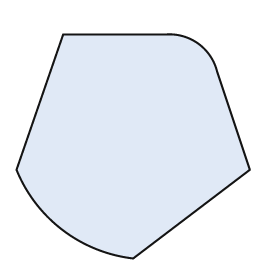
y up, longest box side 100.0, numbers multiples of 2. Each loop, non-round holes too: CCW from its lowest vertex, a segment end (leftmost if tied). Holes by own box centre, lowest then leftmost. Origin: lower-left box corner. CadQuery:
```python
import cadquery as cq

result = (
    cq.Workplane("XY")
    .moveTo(50.0, 0.0)
    .lineTo(100.0, 38.0)
    .lineTo(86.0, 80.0)
    .threePointArc((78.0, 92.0), (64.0, 96.0))
    .lineTo(20.0, 96.0)
    .lineTo(0.0, 38.0)
    .threePointArc((20.0, 12.0), (50.0, 0.0))
    .close()
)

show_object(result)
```